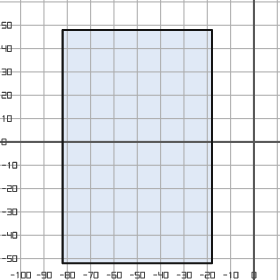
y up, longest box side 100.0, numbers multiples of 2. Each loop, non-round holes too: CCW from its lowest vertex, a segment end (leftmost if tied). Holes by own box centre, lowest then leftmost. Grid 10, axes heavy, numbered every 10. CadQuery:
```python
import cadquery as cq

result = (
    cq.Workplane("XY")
    .moveTo(-82.0, -52.0)
    .lineTo(-18.0, -52.0)
    .lineTo(-18.0, 48.0)
    .lineTo(-82.0, 48.0)
    .close()
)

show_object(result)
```